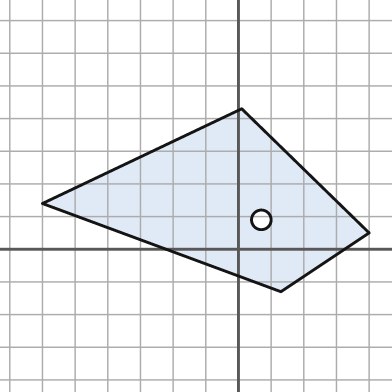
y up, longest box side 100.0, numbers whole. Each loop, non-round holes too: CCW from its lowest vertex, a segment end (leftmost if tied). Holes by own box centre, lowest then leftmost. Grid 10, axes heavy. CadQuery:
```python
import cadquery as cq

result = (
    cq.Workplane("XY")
    .moveTo(13.0, -13.0)
    .lineTo(40.0, 5.0)
    .lineTo(1.0, 43.0)
    .lineTo(-60.0, 14.0)
    .close()
    .moveTo(7.0, 9.0)
    .circle(3.0)
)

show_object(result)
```